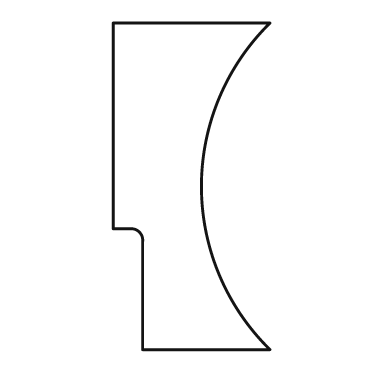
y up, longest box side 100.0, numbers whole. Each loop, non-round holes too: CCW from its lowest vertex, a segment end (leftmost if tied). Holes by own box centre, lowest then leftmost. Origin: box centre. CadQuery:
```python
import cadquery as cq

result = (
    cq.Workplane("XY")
    .moveTo(-15.0, -50.0)
    .lineTo(24.0, -50.0)
    .threePointArc((3.0, 0.0), (24.0, 50.0))
    .lineTo(-24.0, 50.0)
    .lineTo(-24.0, -13.0)
    .lineTo(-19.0, -13.0)
    .threePointArc((-16.0, -14.0), (-15.0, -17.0))
    .close()
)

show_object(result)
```